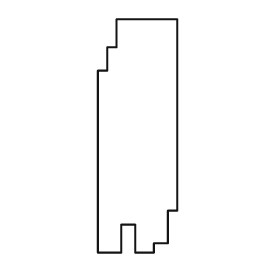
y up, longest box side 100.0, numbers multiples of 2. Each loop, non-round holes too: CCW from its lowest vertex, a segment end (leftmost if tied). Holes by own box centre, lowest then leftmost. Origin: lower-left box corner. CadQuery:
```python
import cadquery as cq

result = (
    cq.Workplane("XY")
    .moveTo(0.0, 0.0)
    .lineTo(10.0, 0.0)
    .lineTo(10.0, 12.0)
    .lineTo(16.0, 12.0)
    .lineTo(16.0, 0.0)
    .lineTo(24.0, 0.0)
    .lineTo(24.0, 4.0)
    .lineTo(30.0, 4.0)
    .lineTo(30.0, 18.0)
    .lineTo(34.0, 18.0)
    .lineTo(34.0, 100.0)
    .lineTo(8.0, 100.0)
    .lineTo(8.0, 88.0)
    .lineTo(4.0, 88.0)
    .lineTo(4.0, 78.0)
    .lineTo(0.0, 78.0)
    .close()
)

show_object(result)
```